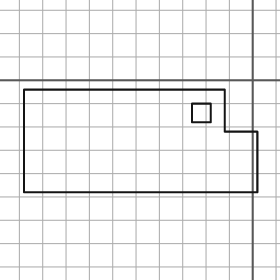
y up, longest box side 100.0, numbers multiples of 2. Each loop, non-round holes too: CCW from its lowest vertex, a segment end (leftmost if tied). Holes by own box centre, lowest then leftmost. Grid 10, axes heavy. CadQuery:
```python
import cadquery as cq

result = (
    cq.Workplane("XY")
    .moveTo(-98.0, -48.0)
    .lineTo(2.0, -48.0)
    .lineTo(2.0, -22.0)
    .lineTo(-12.0, -22.0)
    .lineTo(-12.0, -4.0)
    .lineTo(-98.0, -4.0)
    .close()
    .moveTo(-26.0, -18.0)
    .lineTo(-18.0, -18.0)
    .lineTo(-18.0, -10.0)
    .lineTo(-26.0, -10.0)
    .close()
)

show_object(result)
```